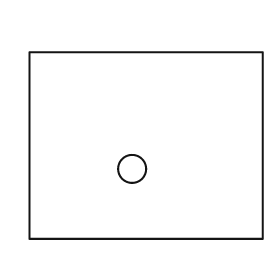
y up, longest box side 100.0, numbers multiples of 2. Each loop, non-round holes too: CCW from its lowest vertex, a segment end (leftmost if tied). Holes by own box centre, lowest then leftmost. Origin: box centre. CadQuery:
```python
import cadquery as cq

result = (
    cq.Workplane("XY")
    .moveTo(-50.0, -40.0)
    .lineTo(50.0, -40.0)
    .lineTo(50.0, 40.0)
    .lineTo(-50.0, 40.0)
    .close()
    .moveTo(-6.0, -10.0)
    .circle(6.0)
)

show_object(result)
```